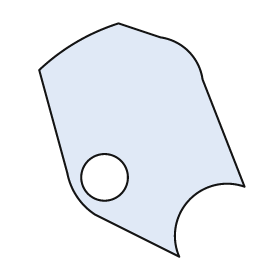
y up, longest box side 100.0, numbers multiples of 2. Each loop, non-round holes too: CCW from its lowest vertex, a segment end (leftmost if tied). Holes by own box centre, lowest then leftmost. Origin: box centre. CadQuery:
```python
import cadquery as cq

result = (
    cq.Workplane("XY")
    .moveTo(16.0, -50.0)
    .threePointArc((20.0, -26.0), (44.0, -20.0))
    .lineTo(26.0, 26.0)
    .threePointArc((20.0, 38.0), (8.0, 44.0))
    .lineTo(-10.0, 50.0)
    .threePointArc((-28.0, 42.0), (-44.0, 30.0))
    .lineTo(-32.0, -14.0)
    .threePointArc((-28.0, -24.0), (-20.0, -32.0))
    .close()
    .moveTo(-16.0, -16.0)
    .circle(10.0)
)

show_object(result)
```